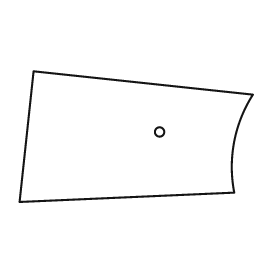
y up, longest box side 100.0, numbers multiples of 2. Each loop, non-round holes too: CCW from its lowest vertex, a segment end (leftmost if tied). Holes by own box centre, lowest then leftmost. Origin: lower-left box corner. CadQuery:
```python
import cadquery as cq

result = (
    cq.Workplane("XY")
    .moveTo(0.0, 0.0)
    .lineTo(92.0, 4.0)
    .threePointArc((92.0, 26.0), (100.0, 46.0))
    .lineTo(6.0, 56.0)
    .close()
    .moveTo(60.0, 30.0)
    .circle(2.0)
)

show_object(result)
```